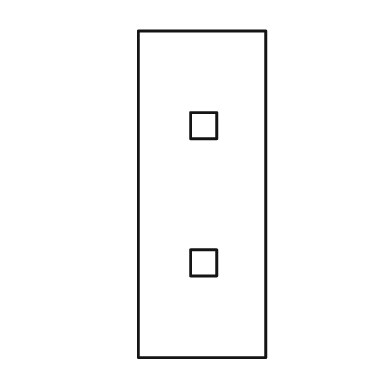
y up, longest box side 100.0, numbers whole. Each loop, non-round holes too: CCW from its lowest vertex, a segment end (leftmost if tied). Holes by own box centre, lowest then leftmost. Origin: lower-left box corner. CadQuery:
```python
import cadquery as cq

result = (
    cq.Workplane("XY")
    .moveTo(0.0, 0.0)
    .lineTo(39.0, 0.0)
    .lineTo(39.0, 100.0)
    .lineTo(0.0, 100.0)
    .close()
    .moveTo(16.0, 25.0)
    .lineTo(24.0, 25.0)
    .lineTo(24.0, 33.0)
    .lineTo(16.0, 33.0)
    .close()
    .moveTo(16.0, 67.0)
    .lineTo(24.0, 67.0)
    .lineTo(24.0, 75.0)
    .lineTo(16.0, 75.0)
    .close()
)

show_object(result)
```